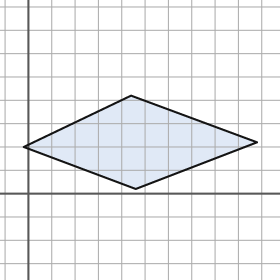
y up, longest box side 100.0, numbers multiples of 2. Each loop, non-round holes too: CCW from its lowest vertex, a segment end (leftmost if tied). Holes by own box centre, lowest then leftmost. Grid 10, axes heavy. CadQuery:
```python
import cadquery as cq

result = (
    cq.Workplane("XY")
    .moveTo(46.0, 2.0)
    .lineTo(98.0, 22.0)
    .lineTo(44.0, 42.0)
    .lineTo(-2.0, 20.0)
    .close()
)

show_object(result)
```